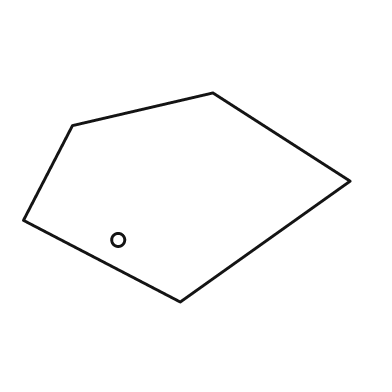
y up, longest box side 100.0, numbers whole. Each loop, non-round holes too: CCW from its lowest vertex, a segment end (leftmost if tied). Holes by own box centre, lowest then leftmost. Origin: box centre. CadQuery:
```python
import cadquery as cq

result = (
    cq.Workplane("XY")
    .moveTo(-2.0, -32.0)
    .lineTo(50.0, 5.0)
    .lineTo(8.0, 32.0)
    .lineTo(-35.0, 22.0)
    .lineTo(-50.0, -7.0)
    .close()
    .moveTo(-21.0, -13.0)
    .circle(2.0)
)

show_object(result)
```